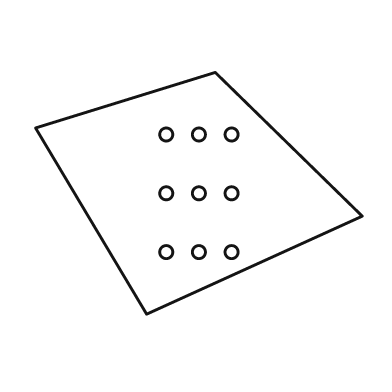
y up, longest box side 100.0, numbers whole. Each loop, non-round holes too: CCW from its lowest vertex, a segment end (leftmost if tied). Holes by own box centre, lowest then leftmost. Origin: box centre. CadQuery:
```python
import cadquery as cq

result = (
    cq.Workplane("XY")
    .moveTo(-16.0, -37.0)
    .lineTo(50.0, -7.0)
    .lineTo(5.0, 37.0)
    .lineTo(-50.0, 20.0)
    .close()
    .moveTo(-10.0, -18.0)
    .circle(2.0)
    .moveTo(0.0, -18.0)
    .circle(2.0)
    .moveTo(10.0, -18.0)
    .circle(2.0)
    .moveTo(-10.0, 0.0)
    .circle(2.0)
    .moveTo(0.0, 0.0)
    .circle(2.0)
    .moveTo(10.0, 0.0)
    .circle(2.0)
    .moveTo(-10.0, 18.0)
    .circle(2.0)
    .moveTo(0.0, 18.0)
    .circle(2.0)
    .moveTo(10.0, 18.0)
    .circle(2.0)
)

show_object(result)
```